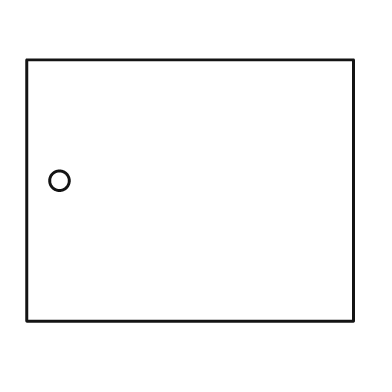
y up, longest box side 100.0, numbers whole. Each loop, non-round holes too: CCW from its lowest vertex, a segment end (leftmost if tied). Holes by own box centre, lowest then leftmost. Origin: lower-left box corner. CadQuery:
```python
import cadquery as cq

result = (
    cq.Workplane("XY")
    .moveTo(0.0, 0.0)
    .lineTo(100.0, 0.0)
    .lineTo(100.0, 80.0)
    .lineTo(0.0, 80.0)
    .close()
    .moveTo(10.0, 43.0)
    .circle(3.0)
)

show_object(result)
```